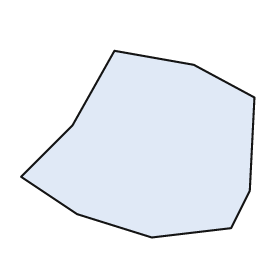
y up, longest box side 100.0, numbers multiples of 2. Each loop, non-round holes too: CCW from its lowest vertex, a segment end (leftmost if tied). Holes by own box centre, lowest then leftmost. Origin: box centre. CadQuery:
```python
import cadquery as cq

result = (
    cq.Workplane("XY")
    .moveTo(6.0, -40.0)
    .lineTo(40.0, -36.0)
    .lineTo(48.0, -20.0)
    .lineTo(50.0, 20.0)
    .lineTo(24.0, 34.0)
    .lineTo(-10.0, 40.0)
    .lineTo(-28.0, 8.0)
    .lineTo(-50.0, -14.0)
    .lineTo(-26.0, -30.0)
    .close()
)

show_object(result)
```